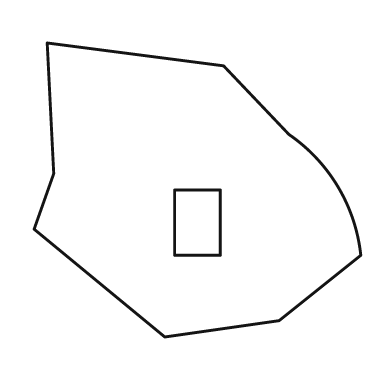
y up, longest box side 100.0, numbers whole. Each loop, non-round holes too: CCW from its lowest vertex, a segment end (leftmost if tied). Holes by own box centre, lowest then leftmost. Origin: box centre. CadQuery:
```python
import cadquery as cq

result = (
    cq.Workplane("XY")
    .moveTo(-10.0, -45.0)
    .lineTo(25.0, -40.0)
    .lineTo(50.0, -20.0)
    .threePointArc((43.0, 1.0), (28.0, 17.0))
    .lineTo(8.0, 38.0)
    .lineTo(-46.0, 45.0)
    .lineTo(-44.0, 5.0)
    .lineTo(-50.0, -12.0)
    .close()
    .moveTo(-7.0, -20.0)
    .lineTo(7.0, -20.0)
    .lineTo(7.0, 0.0)
    .lineTo(-7.0, 0.0)
    .close()
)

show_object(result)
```